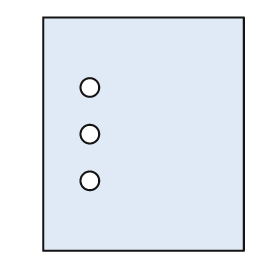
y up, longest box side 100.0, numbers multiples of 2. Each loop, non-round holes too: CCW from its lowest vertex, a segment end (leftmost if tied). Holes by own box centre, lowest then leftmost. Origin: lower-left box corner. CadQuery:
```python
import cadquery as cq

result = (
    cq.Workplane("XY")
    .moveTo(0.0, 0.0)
    .lineTo(86.0, 0.0)
    .lineTo(86.0, 100.0)
    .lineTo(0.0, 100.0)
    .close()
    .moveTo(20.0, 30.0)
    .circle(4.0)
    .moveTo(20.0, 50.0)
    .circle(4.0)
    .moveTo(20.0, 70.0)
    .circle(4.0)
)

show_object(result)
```